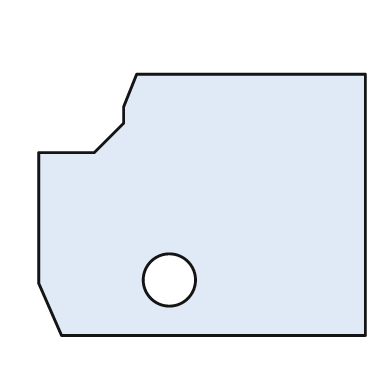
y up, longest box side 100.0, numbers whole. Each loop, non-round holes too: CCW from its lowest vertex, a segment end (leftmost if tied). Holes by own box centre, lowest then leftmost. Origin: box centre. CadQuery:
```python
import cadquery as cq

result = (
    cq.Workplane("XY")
    .moveTo(-43.0, -40.0)
    .lineTo(50.0, -40.0)
    .lineTo(50.0, 40.0)
    .lineTo(-20.0, 40.0)
    .lineTo(-24.0, 30.0)
    .lineTo(-24.0, 25.0)
    .lineTo(-33.0, 16.0)
    .lineTo(-50.0, 16.0)
    .lineTo(-50.0, -24.0)
    .close()
    .moveTo(-10.0, -23.0)
    .circle(8.0)
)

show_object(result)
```